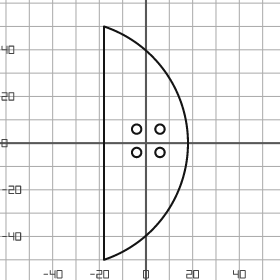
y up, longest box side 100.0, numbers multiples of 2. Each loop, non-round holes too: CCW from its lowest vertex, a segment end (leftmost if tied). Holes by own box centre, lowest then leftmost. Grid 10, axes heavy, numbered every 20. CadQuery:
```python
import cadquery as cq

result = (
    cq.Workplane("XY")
    .moveTo(-18.0, -50.0)
    .threePointArc((18.0, 0.0), (-18.0, 50.0))
    .close()
    .moveTo(-4.0, -4.0)
    .circle(2.0)
    .moveTo(6.0, -4.0)
    .circle(2.0)
    .moveTo(-4.0, 6.0)
    .circle(2.0)
    .moveTo(6.0, 6.0)
    .circle(2.0)
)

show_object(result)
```